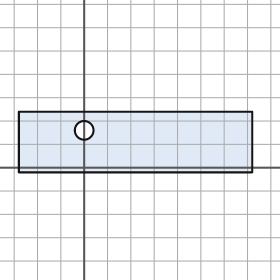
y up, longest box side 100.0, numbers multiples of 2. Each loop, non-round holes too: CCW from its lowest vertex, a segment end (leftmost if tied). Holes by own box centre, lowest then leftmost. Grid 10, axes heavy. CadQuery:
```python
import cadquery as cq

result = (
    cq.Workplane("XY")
    .moveTo(-28.0, -2.0)
    .lineTo(72.0, -2.0)
    .lineTo(72.0, 24.0)
    .lineTo(-28.0, 24.0)
    .close()
    .moveTo(0.0, 16.0)
    .circle(4.0)
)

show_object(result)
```